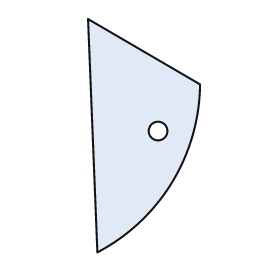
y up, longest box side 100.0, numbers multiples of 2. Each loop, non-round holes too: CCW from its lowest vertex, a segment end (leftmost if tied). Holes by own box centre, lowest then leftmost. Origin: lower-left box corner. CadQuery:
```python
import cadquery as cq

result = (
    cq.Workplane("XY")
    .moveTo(4.0, 0.0)
    .threePointArc((36.0, 30.0), (48.0, 72.0))
    .lineTo(0.0, 100.0)
    .close()
    .moveTo(30.0, 52.0)
    .circle(4.0)
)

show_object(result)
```